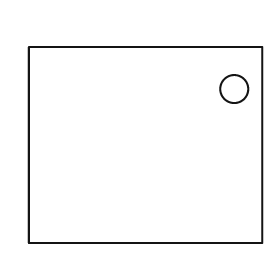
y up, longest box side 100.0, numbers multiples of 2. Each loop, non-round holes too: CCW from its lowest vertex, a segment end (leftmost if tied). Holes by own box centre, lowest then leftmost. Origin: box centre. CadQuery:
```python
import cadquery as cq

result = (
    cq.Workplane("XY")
    .moveTo(-50.0, -42.0)
    .lineTo(50.0, -42.0)
    .lineTo(50.0, 42.0)
    .lineTo(-50.0, 42.0)
    .close()
    .moveTo(38.0, 24.0)
    .circle(6.0)
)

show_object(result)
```